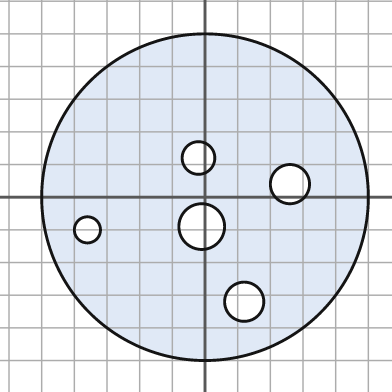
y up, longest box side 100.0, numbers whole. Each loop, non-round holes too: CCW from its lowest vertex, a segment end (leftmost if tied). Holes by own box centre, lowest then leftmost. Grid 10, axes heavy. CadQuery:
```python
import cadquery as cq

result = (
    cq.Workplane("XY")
    .moveTo(0.0, 0.0)
    .circle(50.0)
    .moveTo(12.0, -32.0)
    .circle(6.0)
    .moveTo(-36.0, -10.0)
    .circle(4.0)
    .moveTo(-1.0, -9.0)
    .circle(7.0)
    .moveTo(26.0, 4.0)
    .circle(6.0)
    .moveTo(-2.0, 12.0)
    .circle(5.0)
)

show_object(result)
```